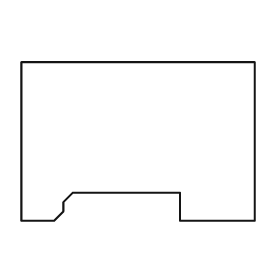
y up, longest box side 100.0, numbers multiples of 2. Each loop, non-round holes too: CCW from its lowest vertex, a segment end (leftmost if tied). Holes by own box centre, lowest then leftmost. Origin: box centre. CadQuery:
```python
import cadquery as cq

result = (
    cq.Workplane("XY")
    .moveTo(-50.0, -34.0)
    .lineTo(-36.0, -34.0)
    .lineTo(-32.0, -30.0)
    .lineTo(-32.0, -26.0)
    .lineTo(-28.0, -22.0)
    .lineTo(18.0, -22.0)
    .lineTo(18.0, -34.0)
    .lineTo(50.0, -34.0)
    .lineTo(50.0, 34.0)
    .lineTo(-50.0, 34.0)
    .close()
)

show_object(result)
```